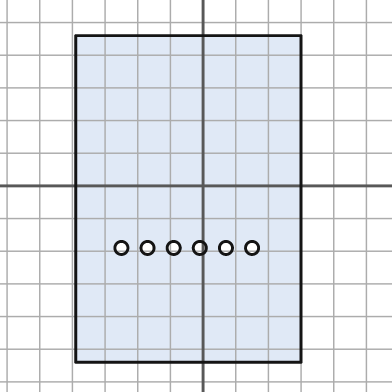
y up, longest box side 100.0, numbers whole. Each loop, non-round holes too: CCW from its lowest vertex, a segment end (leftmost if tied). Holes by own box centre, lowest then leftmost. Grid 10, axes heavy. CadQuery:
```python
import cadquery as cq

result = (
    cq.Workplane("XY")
    .moveTo(-39.0, -54.0)
    .lineTo(30.0, -54.0)
    .lineTo(30.0, 46.0)
    .lineTo(-39.0, 46.0)
    .close()
    .moveTo(-25.0, -19.0)
    .circle(2.0)
    .moveTo(-17.0, -19.0)
    .circle(2.0)
    .moveTo(-9.0, -19.0)
    .circle(2.0)
    .moveTo(-1.0, -19.0)
    .circle(2.0)
    .moveTo(7.0, -19.0)
    .circle(2.0)
    .moveTo(15.0, -19.0)
    .circle(2.0)
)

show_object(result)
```